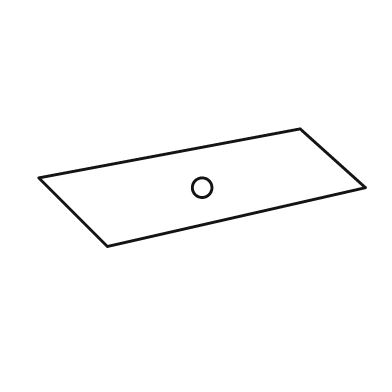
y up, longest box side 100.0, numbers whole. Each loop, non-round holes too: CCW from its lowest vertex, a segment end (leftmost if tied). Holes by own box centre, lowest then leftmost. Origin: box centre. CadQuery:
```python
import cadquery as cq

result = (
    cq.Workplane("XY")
    .moveTo(-29.0, -18.0)
    .lineTo(50.0, 0.0)
    .lineTo(30.0, 18.0)
    .lineTo(-50.0, 3.0)
    .close()
    .moveTo(0.0, 0.0)
    .circle(3.0)
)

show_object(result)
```